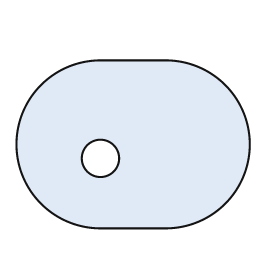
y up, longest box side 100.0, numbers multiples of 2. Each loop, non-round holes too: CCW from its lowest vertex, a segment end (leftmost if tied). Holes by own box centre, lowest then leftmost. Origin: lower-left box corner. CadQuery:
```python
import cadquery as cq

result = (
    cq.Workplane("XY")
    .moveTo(36.0, 0.0)
    .lineTo(64.0, 0.0)
    .threePointArc((100.0, 36.0), (64.0, 72.0))
    .lineTo(36.0, 72.0)
    .threePointArc((0.0, 36.0), (36.0, 0.0))
    .close()
    .moveTo(36.0, 30.0)
    .circle(8.0)
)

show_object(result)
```